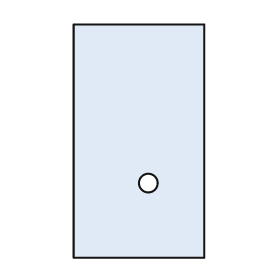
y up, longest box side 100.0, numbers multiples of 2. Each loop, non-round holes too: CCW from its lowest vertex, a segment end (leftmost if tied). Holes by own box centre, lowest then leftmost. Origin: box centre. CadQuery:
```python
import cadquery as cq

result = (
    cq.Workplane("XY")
    .moveTo(-28.0, -50.0)
    .lineTo(28.0, -50.0)
    .lineTo(28.0, 50.0)
    .lineTo(-28.0, 50.0)
    .close()
    .moveTo(4.0, -18.0)
    .circle(4.0)
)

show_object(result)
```